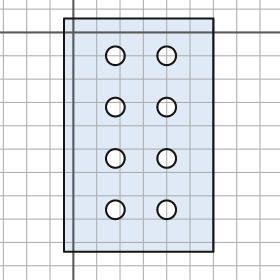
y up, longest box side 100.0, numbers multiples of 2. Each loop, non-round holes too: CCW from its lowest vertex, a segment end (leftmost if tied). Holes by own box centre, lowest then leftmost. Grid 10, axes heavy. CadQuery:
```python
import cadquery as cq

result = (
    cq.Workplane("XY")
    .moveTo(-4.0, -94.0)
    .lineTo(60.0, -94.0)
    .lineTo(60.0, 6.0)
    .lineTo(-4.0, 6.0)
    .close()
    .moveTo(18.0, -76.0)
    .circle(4.0)
    .moveTo(40.0, -76.0)
    .circle(4.0)
    .moveTo(18.0, -54.0)
    .circle(4.0)
    .moveTo(40.0, -54.0)
    .circle(4.0)
    .moveTo(18.0, -32.0)
    .circle(4.0)
    .moveTo(40.0, -32.0)
    .circle(4.0)
    .moveTo(18.0, -10.0)
    .circle(4.0)
    .moveTo(40.0, -10.0)
    .circle(4.0)
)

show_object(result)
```